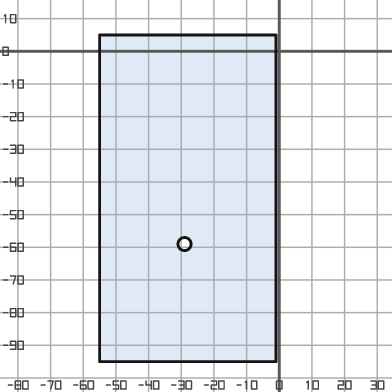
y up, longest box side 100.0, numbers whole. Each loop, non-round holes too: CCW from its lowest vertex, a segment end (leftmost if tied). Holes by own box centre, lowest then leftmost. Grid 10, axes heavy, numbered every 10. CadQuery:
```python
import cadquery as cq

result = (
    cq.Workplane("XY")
    .moveTo(-55.0, -95.0)
    .lineTo(-1.0, -95.0)
    .lineTo(-1.0, 5.0)
    .lineTo(-55.0, 5.0)
    .close()
    .moveTo(-29.0, -59.0)
    .circle(2.0)
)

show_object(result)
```